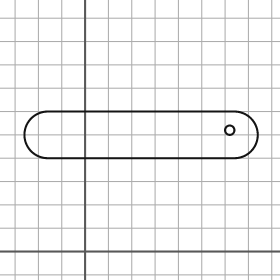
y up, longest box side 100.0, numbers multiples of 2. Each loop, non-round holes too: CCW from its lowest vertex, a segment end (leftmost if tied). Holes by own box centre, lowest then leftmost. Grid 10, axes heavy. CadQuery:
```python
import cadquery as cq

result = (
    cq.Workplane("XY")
    .moveTo(-16.0, 40.0)
    .lineTo(64.0, 40.0)
    .threePointArc((74.0, 50.0), (64.0, 60.0))
    .lineTo(-16.0, 60.0)
    .threePointArc((-26.0, 50.0), (-16.0, 40.0))
    .close()
    .moveTo(62.0, 52.0)
    .circle(2.0)
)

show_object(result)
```